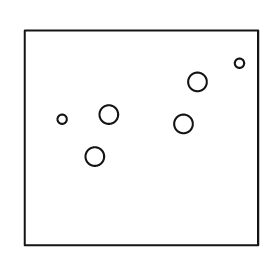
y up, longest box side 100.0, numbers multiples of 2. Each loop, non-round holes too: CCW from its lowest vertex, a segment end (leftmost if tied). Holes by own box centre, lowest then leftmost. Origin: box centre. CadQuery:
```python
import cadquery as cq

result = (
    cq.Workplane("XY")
    .moveTo(-50.0, -46.0)
    .lineTo(50.0, -46.0)
    .lineTo(50.0, 46.0)
    .lineTo(-50.0, 46.0)
    .close()
    .moveTo(-20.0, -8.0)
    .circle(4.0)
    .moveTo(18.0, 6.0)
    .circle(4.0)
    .moveTo(-34.0, 8.0)
    .circle(2.0)
    .moveTo(-14.0, 10.0)
    .circle(4.0)
    .moveTo(24.0, 24.0)
    .circle(4.0)
    .moveTo(42.0, 32.0)
    .circle(2.0)
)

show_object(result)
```